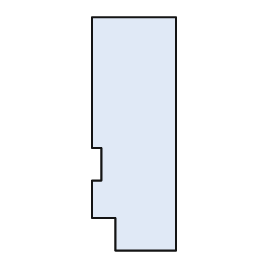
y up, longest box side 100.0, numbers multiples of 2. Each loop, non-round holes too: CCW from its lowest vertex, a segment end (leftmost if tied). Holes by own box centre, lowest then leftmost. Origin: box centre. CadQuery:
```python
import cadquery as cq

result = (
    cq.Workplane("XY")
    .moveTo(-8.0, -50.0)
    .lineTo(18.0, -50.0)
    .lineTo(18.0, 50.0)
    .lineTo(-18.0, 50.0)
    .lineTo(-18.0, -6.0)
    .lineTo(-14.0, -6.0)
    .lineTo(-14.0, -20.0)
    .lineTo(-18.0, -20.0)
    .lineTo(-18.0, -36.0)
    .lineTo(-8.0, -36.0)
    .close()
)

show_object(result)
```